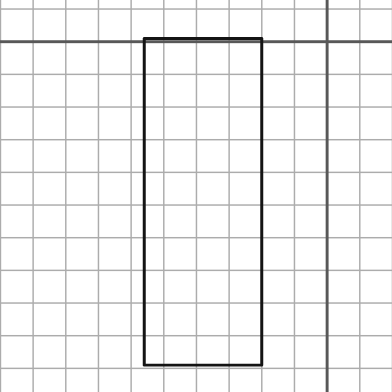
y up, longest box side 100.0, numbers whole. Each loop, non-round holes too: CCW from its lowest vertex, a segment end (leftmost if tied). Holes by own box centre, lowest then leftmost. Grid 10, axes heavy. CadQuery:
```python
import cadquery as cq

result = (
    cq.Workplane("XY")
    .moveTo(-56.0, -99.0)
    .lineTo(-20.0, -99.0)
    .lineTo(-20.0, 1.0)
    .lineTo(-56.0, 1.0)
    .close()
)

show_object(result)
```